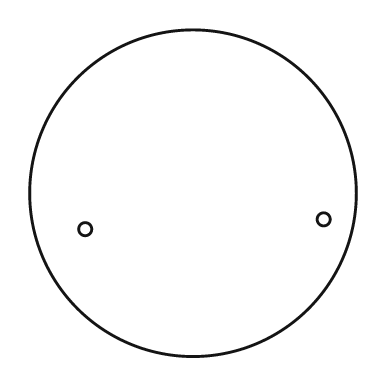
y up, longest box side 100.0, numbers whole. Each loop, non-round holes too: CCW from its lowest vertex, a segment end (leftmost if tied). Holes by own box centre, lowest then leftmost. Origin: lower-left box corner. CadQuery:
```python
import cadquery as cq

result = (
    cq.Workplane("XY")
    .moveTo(50.0, 50.0)
    .circle(50.0)
    .moveTo(17.0, 39.0)
    .circle(2.0)
    .moveTo(90.0, 42.0)
    .circle(2.0)
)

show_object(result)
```